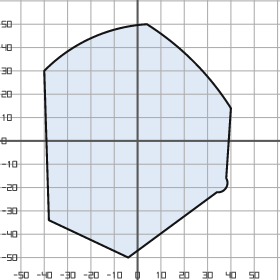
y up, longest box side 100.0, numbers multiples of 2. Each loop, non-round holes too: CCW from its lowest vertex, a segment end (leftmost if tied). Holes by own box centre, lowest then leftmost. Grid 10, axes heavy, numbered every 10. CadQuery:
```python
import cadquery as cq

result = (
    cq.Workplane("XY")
    .moveTo(-4.0, -50.0)
    .lineTo(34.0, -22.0)
    .threePointArc((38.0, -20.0), (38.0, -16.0))
    .lineTo(40.0, 14.0)
    .threePointArc((24.0, 34.0), (4.0, 50.0))
    .threePointArc((-20.0, 44.0), (-40.0, 30.0))
    .lineTo(-38.0, -34.0)
    .close()
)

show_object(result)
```